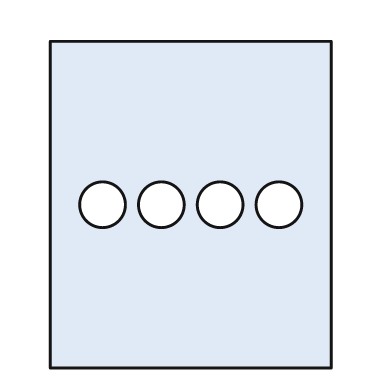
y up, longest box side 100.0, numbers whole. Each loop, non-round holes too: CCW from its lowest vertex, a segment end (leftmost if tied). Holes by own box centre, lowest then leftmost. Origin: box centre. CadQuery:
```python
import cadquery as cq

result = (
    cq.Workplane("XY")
    .moveTo(-43.0, -50.0)
    .lineTo(43.0, -50.0)
    .lineTo(43.0, 50.0)
    .lineTo(-43.0, 50.0)
    .close()
    .moveTo(-27.0, 0.0)
    .circle(7.0)
    .moveTo(-9.0, 0.0)
    .circle(7.0)
    .moveTo(9.0, 0.0)
    .circle(7.0)
    .moveTo(27.0, 0.0)
    .circle(7.0)
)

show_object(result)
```